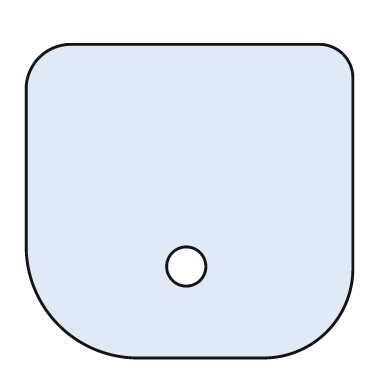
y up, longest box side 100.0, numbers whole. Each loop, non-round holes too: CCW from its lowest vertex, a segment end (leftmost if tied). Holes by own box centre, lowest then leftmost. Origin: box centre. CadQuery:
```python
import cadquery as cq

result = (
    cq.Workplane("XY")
    .moveTo(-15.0, -48.0)
    .lineTo(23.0, -48.0)
    .threePointArc((42.0, -40.0), (50.0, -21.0))
    .lineTo(50.0, 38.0)
    .threePointArc((47.0, 45.0), (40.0, 48.0))
    .lineTo(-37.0, 48.0)
    .threePointArc((-46.0, 44.0), (-50.0, 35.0))
    .lineTo(-50.0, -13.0)
    .threePointArc((-40.0, -38.0), (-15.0, -48.0))
    .close()
    .moveTo(-1.0, -20.0)
    .circle(6.0)
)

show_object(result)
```